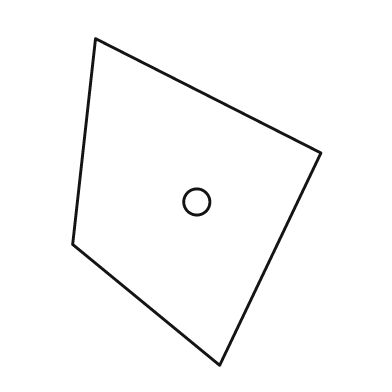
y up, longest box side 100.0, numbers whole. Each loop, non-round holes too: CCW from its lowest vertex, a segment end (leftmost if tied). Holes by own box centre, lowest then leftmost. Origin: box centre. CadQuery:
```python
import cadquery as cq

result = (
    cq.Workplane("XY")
    .moveTo(7.0, -50.0)
    .lineTo(38.0, 15.0)
    .lineTo(-31.0, 50.0)
    .lineTo(-38.0, -13.0)
    .close()
    .moveTo(0.0, 0.0)
    .circle(4.0)
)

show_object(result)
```